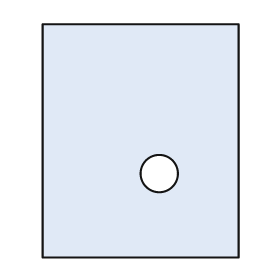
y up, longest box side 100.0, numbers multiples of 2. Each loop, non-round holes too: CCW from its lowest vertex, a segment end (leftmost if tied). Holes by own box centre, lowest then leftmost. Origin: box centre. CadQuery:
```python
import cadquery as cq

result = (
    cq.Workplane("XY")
    .moveTo(-42.0, -50.0)
    .lineTo(42.0, -50.0)
    .lineTo(42.0, 50.0)
    .lineTo(-42.0, 50.0)
    .close()
    .moveTo(8.0, -14.0)
    .circle(8.0)
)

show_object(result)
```